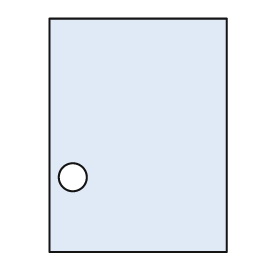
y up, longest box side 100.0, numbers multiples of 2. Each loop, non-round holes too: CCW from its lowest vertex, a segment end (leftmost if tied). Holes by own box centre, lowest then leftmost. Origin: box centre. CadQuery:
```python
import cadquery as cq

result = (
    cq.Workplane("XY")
    .moveTo(-38.0, -50.0)
    .lineTo(38.0, -50.0)
    .lineTo(38.0, 50.0)
    .lineTo(-38.0, 50.0)
    .close()
    .moveTo(-28.0, -18.0)
    .circle(6.0)
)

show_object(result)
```